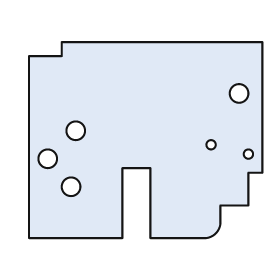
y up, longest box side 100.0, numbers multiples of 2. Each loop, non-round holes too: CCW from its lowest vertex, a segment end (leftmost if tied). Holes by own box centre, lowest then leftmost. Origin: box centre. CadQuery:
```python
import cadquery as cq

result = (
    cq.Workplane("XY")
    .moveTo(-50.0, -42.0)
    .lineTo(-10.0, -42.0)
    .lineTo(-10.0, -12.0)
    .lineTo(2.0, -12.0)
    .lineTo(2.0, -42.0)
    .lineTo(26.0, -42.0)
    .threePointArc((30.0, -40.0), (32.0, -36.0))
    .lineTo(32.0, -28.0)
    .lineTo(44.0, -28.0)
    .lineTo(44.0, -14.0)
    .lineTo(50.0, -14.0)
    .lineTo(50.0, 42.0)
    .lineTo(-36.0, 42.0)
    .lineTo(-36.0, 36.0)
    .lineTo(-50.0, 36.0)
    .close()
    .moveTo(-32.0, -20.0)
    .circle(4.0)
    .moveTo(-42.0, -8.0)
    .circle(4.0)
    .moveTo(44.0, -6.0)
    .circle(2.0)
    .moveTo(28.0, -2.0)
    .circle(2.0)
    .moveTo(-30.0, 4.0)
    .circle(4.0)
    .moveTo(40.0, 20.0)
    .circle(4.0)
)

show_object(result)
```